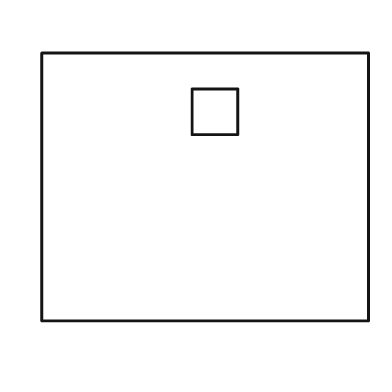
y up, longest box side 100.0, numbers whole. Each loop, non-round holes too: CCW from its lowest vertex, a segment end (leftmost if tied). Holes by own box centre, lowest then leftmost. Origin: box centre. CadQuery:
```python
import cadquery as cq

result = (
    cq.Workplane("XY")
    .moveTo(-50.0, -41.0)
    .lineTo(50.0, -41.0)
    .lineTo(50.0, 41.0)
    .lineTo(-50.0, 41.0)
    .close()
    .moveTo(-4.0, 16.0)
    .lineTo(10.0, 16.0)
    .lineTo(10.0, 30.0)
    .lineTo(-4.0, 30.0)
    .close()
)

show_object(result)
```